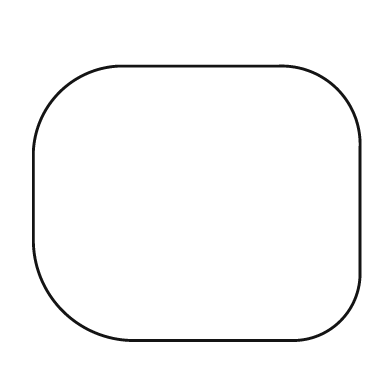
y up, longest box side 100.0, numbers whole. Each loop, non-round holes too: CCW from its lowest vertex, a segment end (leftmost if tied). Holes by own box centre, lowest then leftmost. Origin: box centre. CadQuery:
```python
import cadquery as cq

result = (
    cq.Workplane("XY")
    .moveTo(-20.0, -42.0)
    .lineTo(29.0, -42.0)
    .threePointArc((44.0, -36.0), (50.0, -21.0))
    .lineTo(50.0, 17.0)
    .threePointArc((43.0, 35.0), (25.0, 42.0))
    .lineTo(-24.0, 42.0)
    .threePointArc((-42.0, 34.0), (-50.0, 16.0))
    .lineTo(-50.0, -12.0)
    .threePointArc((-41.0, -33.0), (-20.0, -42.0))
    .close()
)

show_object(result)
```